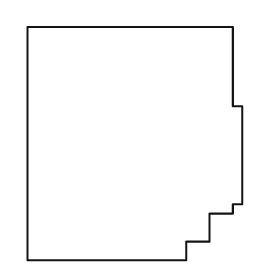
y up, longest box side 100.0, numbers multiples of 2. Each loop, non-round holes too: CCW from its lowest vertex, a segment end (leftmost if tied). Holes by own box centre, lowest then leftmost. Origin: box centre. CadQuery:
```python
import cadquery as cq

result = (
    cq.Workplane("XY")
    .moveTo(-46.0, -50.0)
    .lineTo(22.0, -50.0)
    .lineTo(22.0, -42.0)
    .lineTo(32.0, -42.0)
    .lineTo(32.0, -30.0)
    .lineTo(42.0, -30.0)
    .lineTo(42.0, -26.0)
    .lineTo(46.0, -26.0)
    .lineTo(46.0, 16.0)
    .lineTo(42.0, 16.0)
    .lineTo(42.0, 50.0)
    .lineTo(-46.0, 50.0)
    .close()
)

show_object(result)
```